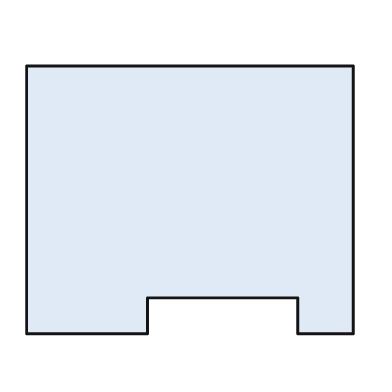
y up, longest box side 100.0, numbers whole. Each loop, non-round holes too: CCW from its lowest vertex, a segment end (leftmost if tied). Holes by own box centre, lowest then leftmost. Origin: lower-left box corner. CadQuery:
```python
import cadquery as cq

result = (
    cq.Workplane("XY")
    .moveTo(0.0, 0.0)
    .lineTo(37.0, 0.0)
    .lineTo(37.0, 11.0)
    .lineTo(83.0, 11.0)
    .lineTo(83.0, 0.0)
    .lineTo(100.0, 0.0)
    .lineTo(100.0, 82.0)
    .lineTo(0.0, 82.0)
    .close()
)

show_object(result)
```